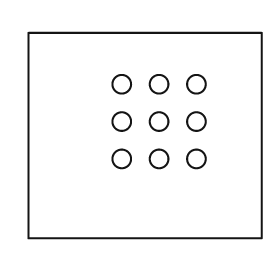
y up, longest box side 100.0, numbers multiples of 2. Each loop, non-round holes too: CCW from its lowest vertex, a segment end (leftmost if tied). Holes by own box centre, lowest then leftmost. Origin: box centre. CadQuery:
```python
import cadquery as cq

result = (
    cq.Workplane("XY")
    .moveTo(-50.0, -44.0)
    .lineTo(50.0, -44.0)
    .lineTo(50.0, 44.0)
    .lineTo(-50.0, 44.0)
    .close()
    .moveTo(-10.0, -10.0)
    .circle(4.0)
    .moveTo(6.0, -10.0)
    .circle(4.0)
    .moveTo(22.0, -10.0)
    .circle(4.0)
    .moveTo(-10.0, 6.0)
    .circle(4.0)
    .moveTo(6.0, 6.0)
    .circle(4.0)
    .moveTo(22.0, 6.0)
    .circle(4.0)
    .moveTo(-10.0, 22.0)
    .circle(4.0)
    .moveTo(6.0, 22.0)
    .circle(4.0)
    .moveTo(22.0, 22.0)
    .circle(4.0)
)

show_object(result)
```